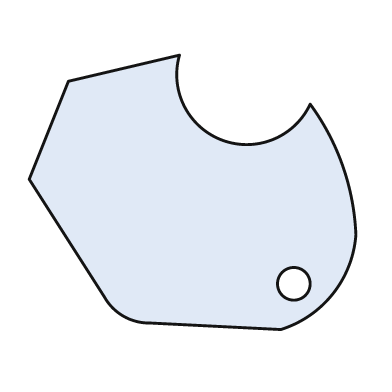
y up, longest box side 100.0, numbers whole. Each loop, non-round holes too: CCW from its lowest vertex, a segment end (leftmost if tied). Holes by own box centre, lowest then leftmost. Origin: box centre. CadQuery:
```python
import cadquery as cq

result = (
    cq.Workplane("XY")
    .moveTo(27.0, -42.0)
    .threePointArc((43.0, -31.0), (50.0, -13.0))
    .threePointArc((46.0, 8.0), (36.0, 27.0))
    .threePointArc((9.0, 16.0), (-4.0, 42.0))
    .lineTo(-38.0, 34.0)
    .lineTo(-50.0, 4.0)
    .lineTo(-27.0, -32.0)
    .threePointArc((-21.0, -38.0), (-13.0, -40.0))
    .close()
    .moveTo(31.0, -28.0)
    .circle(5.0)
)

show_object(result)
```